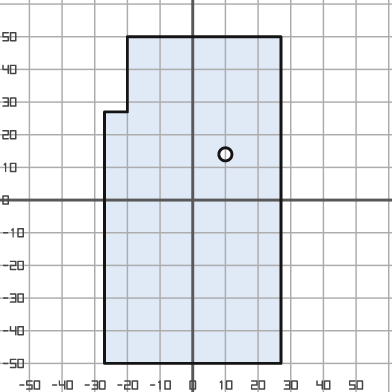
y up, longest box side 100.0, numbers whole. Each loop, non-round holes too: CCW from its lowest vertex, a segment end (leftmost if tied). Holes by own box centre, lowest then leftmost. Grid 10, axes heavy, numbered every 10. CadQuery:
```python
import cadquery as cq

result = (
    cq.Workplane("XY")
    .moveTo(-27.0, -50.0)
    .lineTo(27.0, -50.0)
    .lineTo(27.0, 50.0)
    .lineTo(-20.0, 50.0)
    .lineTo(-20.0, 27.0)
    .lineTo(-27.0, 27.0)
    .close()
    .moveTo(10.0, 14.0)
    .circle(2.0)
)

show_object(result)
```